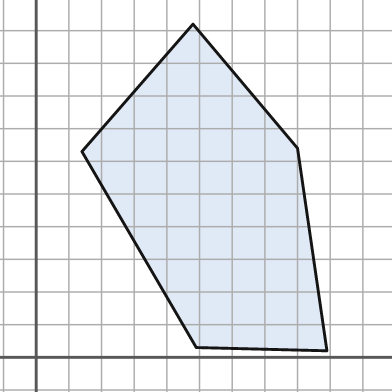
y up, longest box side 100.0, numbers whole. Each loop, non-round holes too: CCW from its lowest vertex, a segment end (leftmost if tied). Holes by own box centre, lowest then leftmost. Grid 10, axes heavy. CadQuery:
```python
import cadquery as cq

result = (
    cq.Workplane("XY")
    .moveTo(89.0, 2.0)
    .lineTo(80.0, 64.0)
    .lineTo(48.0, 102.0)
    .lineTo(14.0, 63.0)
    .lineTo(49.0, 3.0)
    .close()
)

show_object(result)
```